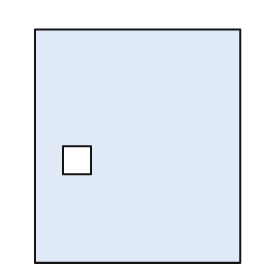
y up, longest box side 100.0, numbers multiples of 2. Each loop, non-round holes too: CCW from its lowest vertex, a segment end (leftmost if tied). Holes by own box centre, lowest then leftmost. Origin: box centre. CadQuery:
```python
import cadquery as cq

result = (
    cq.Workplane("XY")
    .moveTo(-44.0, -50.0)
    .lineTo(44.0, -50.0)
    .lineTo(44.0, 50.0)
    .lineTo(-44.0, 50.0)
    .close()
    .moveTo(-32.0, -12.0)
    .lineTo(-20.0, -12.0)
    .lineTo(-20.0, 0.0)
    .lineTo(-32.0, 0.0)
    .close()
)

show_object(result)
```